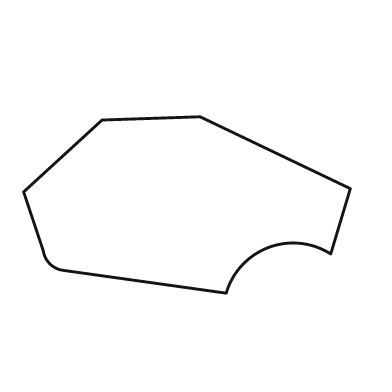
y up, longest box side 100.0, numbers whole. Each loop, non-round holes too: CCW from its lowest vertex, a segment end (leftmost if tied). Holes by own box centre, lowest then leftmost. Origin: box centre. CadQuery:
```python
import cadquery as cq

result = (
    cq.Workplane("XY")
    .moveTo(12.0, -27.0)
    .threePointArc((25.0, -13.0), (44.0, -15.0))
    .lineTo(50.0, 5.0)
    .lineTo(4.0, 27.0)
    .lineTo(-26.0, 26.0)
    .lineTo(-50.0, 4.0)
    .lineTo(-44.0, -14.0)
    .threePointArc((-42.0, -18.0), (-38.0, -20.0))
    .close()
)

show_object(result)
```